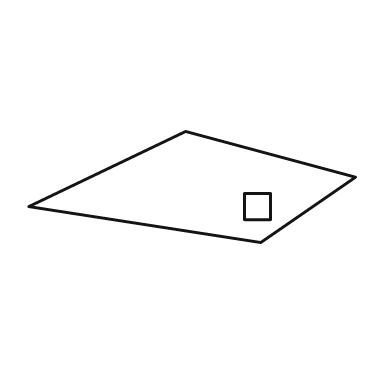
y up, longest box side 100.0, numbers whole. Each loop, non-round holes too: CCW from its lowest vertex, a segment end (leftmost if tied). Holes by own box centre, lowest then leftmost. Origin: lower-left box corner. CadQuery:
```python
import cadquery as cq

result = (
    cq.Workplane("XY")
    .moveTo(71.0, 0.0)
    .lineTo(100.0, 20.0)
    .lineTo(48.0, 34.0)
    .lineTo(0.0, 11.0)
    .close()
    .moveTo(66.0, 7.0)
    .lineTo(74.0, 7.0)
    .lineTo(74.0, 15.0)
    .lineTo(66.0, 15.0)
    .close()
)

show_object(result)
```